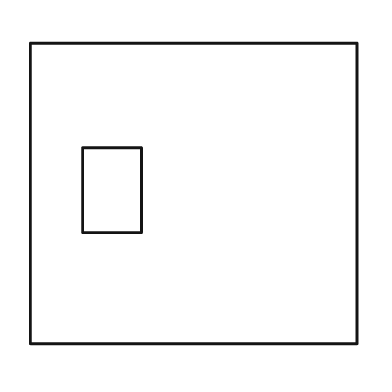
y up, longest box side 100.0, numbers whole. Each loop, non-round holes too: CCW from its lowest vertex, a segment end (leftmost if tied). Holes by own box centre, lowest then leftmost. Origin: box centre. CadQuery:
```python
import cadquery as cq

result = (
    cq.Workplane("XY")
    .moveTo(-50.0, -46.0)
    .lineTo(50.0, -46.0)
    .lineTo(50.0, 46.0)
    .lineTo(-50.0, 46.0)
    .close()
    .moveTo(-34.0, -12.0)
    .lineTo(-16.0, -12.0)
    .lineTo(-16.0, 14.0)
    .lineTo(-34.0, 14.0)
    .close()
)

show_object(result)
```